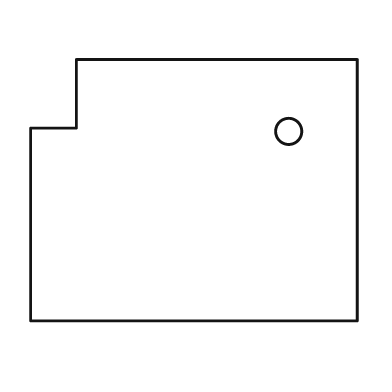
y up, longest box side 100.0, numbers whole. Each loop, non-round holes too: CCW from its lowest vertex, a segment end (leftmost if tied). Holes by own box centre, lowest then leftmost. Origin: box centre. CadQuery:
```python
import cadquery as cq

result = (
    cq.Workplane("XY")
    .moveTo(-50.0, -40.0)
    .lineTo(50.0, -40.0)
    .lineTo(50.0, 40.0)
    .lineTo(-36.0, 40.0)
    .lineTo(-36.0, 19.0)
    .lineTo(-50.0, 19.0)
    .close()
    .moveTo(29.0, 18.0)
    .circle(4.0)
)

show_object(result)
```